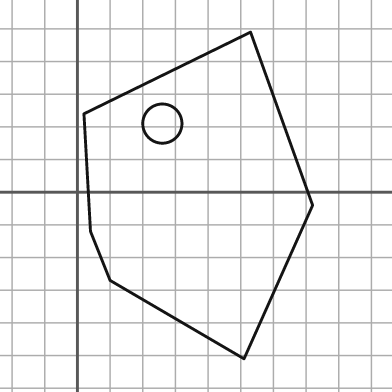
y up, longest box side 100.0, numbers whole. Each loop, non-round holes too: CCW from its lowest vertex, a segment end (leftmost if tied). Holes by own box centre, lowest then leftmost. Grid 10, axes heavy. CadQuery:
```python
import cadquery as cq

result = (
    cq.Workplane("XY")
    .moveTo(51.0, -51.0)
    .lineTo(72.0, -4.0)
    .lineTo(53.0, 49.0)
    .lineTo(2.0, 24.0)
    .lineTo(4.0, -12.0)
    .lineTo(10.0, -27.0)
    .close()
    .moveTo(26.0, 21.0)
    .circle(6.0)
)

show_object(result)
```